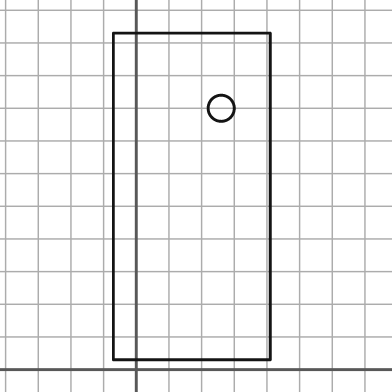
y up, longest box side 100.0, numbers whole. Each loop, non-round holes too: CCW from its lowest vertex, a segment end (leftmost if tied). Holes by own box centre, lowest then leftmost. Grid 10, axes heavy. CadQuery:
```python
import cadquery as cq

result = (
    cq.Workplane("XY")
    .moveTo(-7.0, 3.0)
    .lineTo(41.0, 3.0)
    .lineTo(41.0, 103.0)
    .lineTo(-7.0, 103.0)
    .close()
    .moveTo(26.0, 80.0)
    .circle(4.0)
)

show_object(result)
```